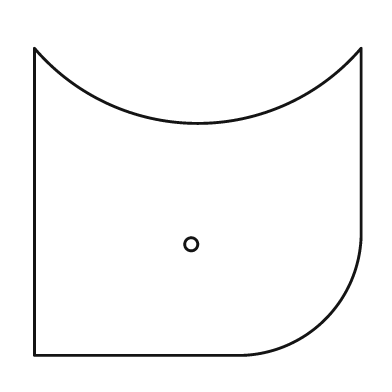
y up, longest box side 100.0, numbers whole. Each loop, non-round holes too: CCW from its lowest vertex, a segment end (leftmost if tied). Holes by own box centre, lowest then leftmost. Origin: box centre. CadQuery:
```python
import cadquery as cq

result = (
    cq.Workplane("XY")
    .moveTo(-50.0, -47.0)
    .lineTo(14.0, -47.0)
    .threePointArc((39.0, -36.0), (50.0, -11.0))
    .lineTo(50.0, 47.0)
    .threePointArc((0.0, 24.0), (-50.0, 47.0))
    .close()
    .moveTo(-2.0, -13.0)
    .circle(2.0)
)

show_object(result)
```